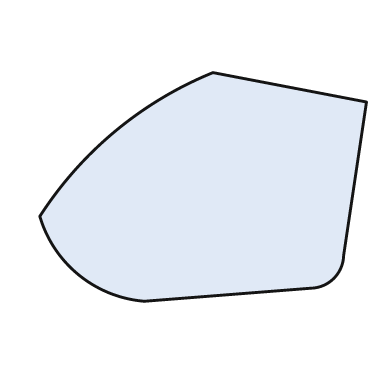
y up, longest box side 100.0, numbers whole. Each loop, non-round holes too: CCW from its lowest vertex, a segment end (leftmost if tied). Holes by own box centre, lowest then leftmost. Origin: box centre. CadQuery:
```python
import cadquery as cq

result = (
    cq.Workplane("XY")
    .moveTo(-18.0, -35.0)
    .lineTo(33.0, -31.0)
    .threePointArc((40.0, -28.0), (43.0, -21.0))
    .lineTo(50.0, 26.0)
    .lineTo(3.0, 35.0)
    .threePointArc((-27.0, 17.0), (-50.0, -9.0))
    .threePointArc((-38.0, -27.0), (-18.0, -35.0))
    .close()
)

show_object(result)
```